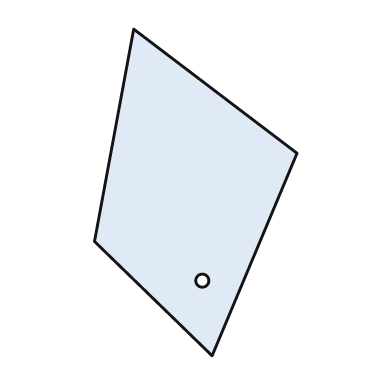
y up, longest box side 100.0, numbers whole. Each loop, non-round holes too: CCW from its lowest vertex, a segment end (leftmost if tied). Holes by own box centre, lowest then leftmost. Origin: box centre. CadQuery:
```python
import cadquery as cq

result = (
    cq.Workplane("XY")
    .moveTo(5.0, -50.0)
    .lineTo(31.0, 12.0)
    .lineTo(-19.0, 50.0)
    .lineTo(-31.0, -15.0)
    .close()
    .moveTo(2.0, -27.0)
    .circle(2.0)
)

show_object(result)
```